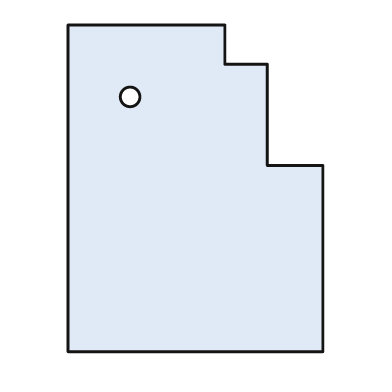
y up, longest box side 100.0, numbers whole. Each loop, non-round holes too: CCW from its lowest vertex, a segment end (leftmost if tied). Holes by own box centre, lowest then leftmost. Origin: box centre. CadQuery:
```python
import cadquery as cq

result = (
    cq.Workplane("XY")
    .moveTo(-39.0, -50.0)
    .lineTo(39.0, -50.0)
    .lineTo(39.0, 7.0)
    .lineTo(22.0, 7.0)
    .lineTo(22.0, 38.0)
    .lineTo(9.0, 38.0)
    .lineTo(9.0, 50.0)
    .lineTo(-39.0, 50.0)
    .close()
    .moveTo(-20.0, 28.0)
    .circle(3.0)
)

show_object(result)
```